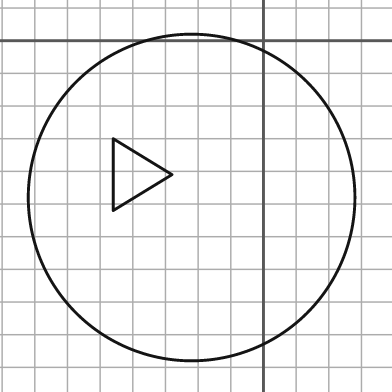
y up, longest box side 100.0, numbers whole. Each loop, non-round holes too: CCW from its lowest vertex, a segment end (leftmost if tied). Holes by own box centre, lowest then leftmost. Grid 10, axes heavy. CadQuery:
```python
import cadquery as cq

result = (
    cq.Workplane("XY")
    .moveTo(-22.0, -48.0)
    .circle(50.0)
    .moveTo(-46.0, -52.0)
    .lineTo(-28.0, -41.0)
    .lineTo(-46.0, -30.0)
    .close()
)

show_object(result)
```